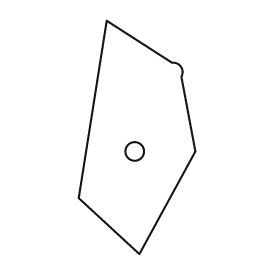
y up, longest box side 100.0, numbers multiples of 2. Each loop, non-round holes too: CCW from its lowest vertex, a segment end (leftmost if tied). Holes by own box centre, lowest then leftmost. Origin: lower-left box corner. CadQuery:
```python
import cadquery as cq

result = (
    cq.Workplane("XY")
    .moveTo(26.0, 0.0)
    .lineTo(50.0, 44.0)
    .lineTo(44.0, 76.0)
    .threePointArc((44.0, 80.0), (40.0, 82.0))
    .lineTo(12.0, 100.0)
    .lineTo(0.0, 24.0)
    .close()
    .moveTo(24.0, 44.0)
    .circle(4.0)
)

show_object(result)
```